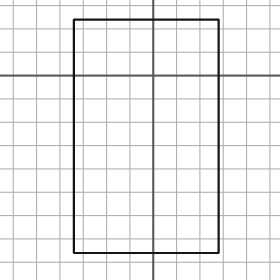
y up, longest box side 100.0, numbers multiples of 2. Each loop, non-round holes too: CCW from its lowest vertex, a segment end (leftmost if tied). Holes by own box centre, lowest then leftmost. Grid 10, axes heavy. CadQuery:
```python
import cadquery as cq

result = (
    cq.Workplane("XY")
    .moveTo(-34.0, -76.0)
    .lineTo(28.0, -76.0)
    .lineTo(28.0, 24.0)
    .lineTo(-34.0, 24.0)
    .close()
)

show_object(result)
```